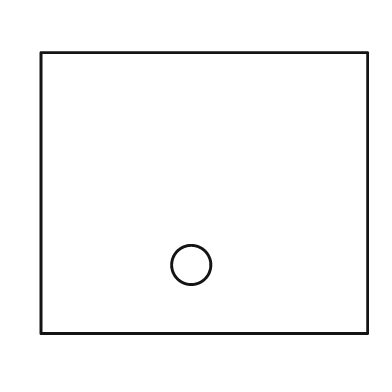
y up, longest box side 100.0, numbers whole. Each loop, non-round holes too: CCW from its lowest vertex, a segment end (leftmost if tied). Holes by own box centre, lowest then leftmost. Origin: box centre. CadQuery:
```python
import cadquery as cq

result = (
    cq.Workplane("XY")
    .moveTo(-50.0, -43.0)
    .lineTo(50.0, -43.0)
    .lineTo(50.0, 43.0)
    .lineTo(-50.0, 43.0)
    .close()
    .moveTo(-4.0, -22.0)
    .circle(6.0)
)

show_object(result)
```